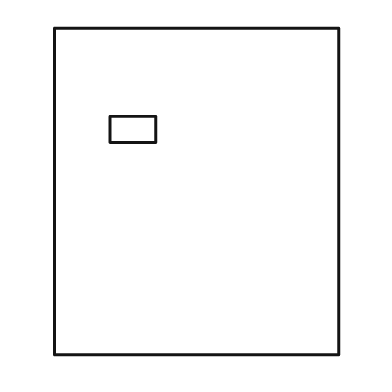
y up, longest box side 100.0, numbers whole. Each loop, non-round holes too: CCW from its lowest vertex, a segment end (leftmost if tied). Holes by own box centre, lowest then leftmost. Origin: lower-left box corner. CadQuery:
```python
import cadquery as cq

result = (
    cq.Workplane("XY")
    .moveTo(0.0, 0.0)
    .lineTo(87.0, 0.0)
    .lineTo(87.0, 100.0)
    .lineTo(0.0, 100.0)
    .close()
    .moveTo(17.0, 65.0)
    .lineTo(31.0, 65.0)
    .lineTo(31.0, 73.0)
    .lineTo(17.0, 73.0)
    .close()
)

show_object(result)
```